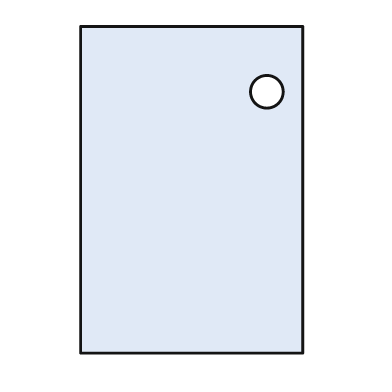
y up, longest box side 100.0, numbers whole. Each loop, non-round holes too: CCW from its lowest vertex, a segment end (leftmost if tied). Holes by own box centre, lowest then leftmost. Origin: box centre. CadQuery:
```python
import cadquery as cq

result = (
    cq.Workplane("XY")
    .moveTo(-34.0, -50.0)
    .lineTo(34.0, -50.0)
    .lineTo(34.0, 50.0)
    .lineTo(-34.0, 50.0)
    .close()
    .moveTo(23.0, 30.0)
    .circle(5.0)
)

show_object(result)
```